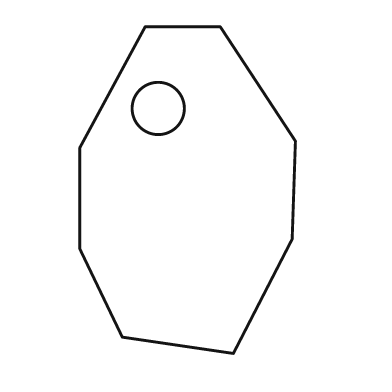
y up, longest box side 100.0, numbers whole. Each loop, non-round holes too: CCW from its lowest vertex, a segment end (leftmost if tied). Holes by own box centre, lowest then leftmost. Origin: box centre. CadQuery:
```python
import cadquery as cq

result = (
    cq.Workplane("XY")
    .moveTo(14.0, -50.0)
    .lineTo(32.0, -15.0)
    .lineTo(33.0, 15.0)
    .lineTo(10.0, 50.0)
    .lineTo(-13.0, 50.0)
    .lineTo(-33.0, 13.0)
    .lineTo(-33.0, -18.0)
    .lineTo(-20.0, -45.0)
    .close()
    .moveTo(-9.0, 25.0)
    .circle(8.0)
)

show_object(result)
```